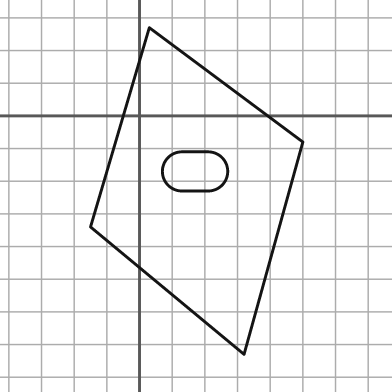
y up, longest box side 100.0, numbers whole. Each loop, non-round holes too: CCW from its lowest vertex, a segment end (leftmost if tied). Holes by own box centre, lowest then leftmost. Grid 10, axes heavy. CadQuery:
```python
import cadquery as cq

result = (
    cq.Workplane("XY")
    .moveTo(32.0, -73.0)
    .lineTo(50.0, -8.0)
    .lineTo(3.0, 27.0)
    .lineTo(-15.0, -34.0)
    .close()
    .moveTo(13.0, -23.0)
    .lineTo(21.0, -23.0)
    .threePointArc((27.0, -17.0), (21.0, -11.0))
    .lineTo(13.0, -11.0)
    .threePointArc((7.0, -17.0), (13.0, -23.0))
    .close()
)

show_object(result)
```